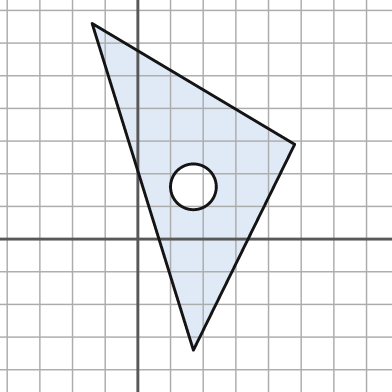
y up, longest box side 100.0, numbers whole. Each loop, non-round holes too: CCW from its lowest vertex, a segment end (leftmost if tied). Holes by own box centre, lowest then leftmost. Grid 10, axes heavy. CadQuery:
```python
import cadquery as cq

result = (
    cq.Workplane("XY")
    .moveTo(17.0, -34.0)
    .lineTo(48.0, 29.0)
    .lineTo(-14.0, 66.0)
    .close()
    .moveTo(17.0, 16.0)
    .circle(7.0)
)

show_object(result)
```